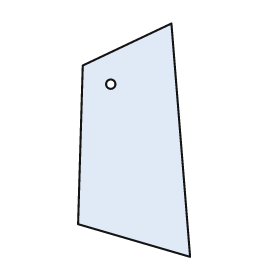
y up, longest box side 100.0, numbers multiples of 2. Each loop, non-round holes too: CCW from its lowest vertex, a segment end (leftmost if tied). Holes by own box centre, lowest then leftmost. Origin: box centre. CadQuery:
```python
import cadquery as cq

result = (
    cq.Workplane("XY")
    .moveTo(24.0, -50.0)
    .lineTo(16.0, 50.0)
    .lineTo(-22.0, 32.0)
    .lineTo(-24.0, -36.0)
    .close()
    .moveTo(-10.0, 24.0)
    .circle(2.0)
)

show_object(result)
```